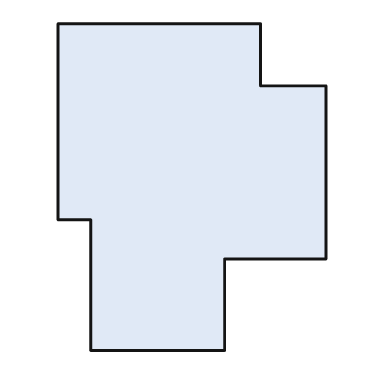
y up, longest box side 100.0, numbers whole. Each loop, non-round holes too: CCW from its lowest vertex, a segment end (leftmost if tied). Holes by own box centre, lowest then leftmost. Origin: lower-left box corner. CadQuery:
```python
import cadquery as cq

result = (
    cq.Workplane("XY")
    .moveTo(10.0, 0.0)
    .lineTo(51.0, 0.0)
    .lineTo(51.0, 28.0)
    .lineTo(82.0, 28.0)
    .lineTo(82.0, 81.0)
    .lineTo(62.0, 81.0)
    .lineTo(62.0, 100.0)
    .lineTo(0.0, 100.0)
    .lineTo(0.0, 40.0)
    .lineTo(10.0, 40.0)
    .close()
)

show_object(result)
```